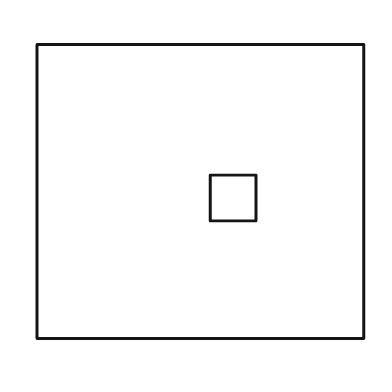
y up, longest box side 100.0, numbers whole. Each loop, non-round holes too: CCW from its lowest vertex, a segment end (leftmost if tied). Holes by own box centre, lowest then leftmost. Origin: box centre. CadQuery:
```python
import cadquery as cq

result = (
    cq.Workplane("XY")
    .moveTo(-50.0, -45.0)
    .lineTo(50.0, -45.0)
    .lineTo(50.0, 45.0)
    .lineTo(-50.0, 45.0)
    .close()
    .moveTo(3.0, -9.0)
    .lineTo(17.0, -9.0)
    .lineTo(17.0, 5.0)
    .lineTo(3.0, 5.0)
    .close()
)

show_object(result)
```